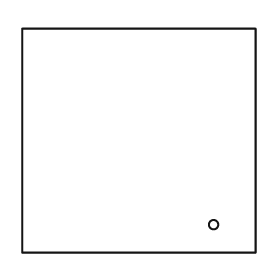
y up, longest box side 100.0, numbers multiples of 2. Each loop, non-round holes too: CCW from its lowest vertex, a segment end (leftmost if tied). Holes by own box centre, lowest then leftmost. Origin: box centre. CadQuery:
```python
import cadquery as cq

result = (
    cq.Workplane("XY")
    .moveTo(-50.0, -48.0)
    .lineTo(50.0, -48.0)
    .lineTo(50.0, 48.0)
    .lineTo(-50.0, 48.0)
    .close()
    .moveTo(32.0, -36.0)
    .circle(2.0)
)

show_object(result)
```